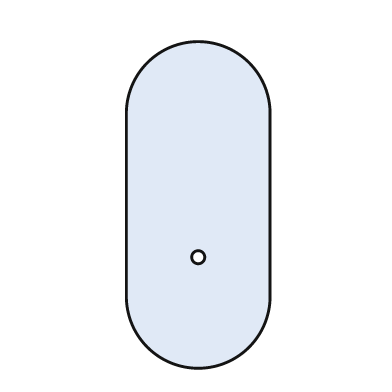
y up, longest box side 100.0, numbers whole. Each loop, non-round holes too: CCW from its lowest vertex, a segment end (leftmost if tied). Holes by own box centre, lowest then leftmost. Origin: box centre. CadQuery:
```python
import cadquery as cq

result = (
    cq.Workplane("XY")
    .moveTo(-22.0, -28.0)
    .threePointArc((0.0, -50.0), (22.0, -28.0))
    .lineTo(22.0, 28.0)
    .threePointArc((0.0, 50.0), (-22.0, 28.0))
    .close()
    .moveTo(0.0, -16.0)
    .circle(2.0)
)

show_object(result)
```